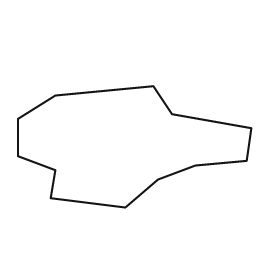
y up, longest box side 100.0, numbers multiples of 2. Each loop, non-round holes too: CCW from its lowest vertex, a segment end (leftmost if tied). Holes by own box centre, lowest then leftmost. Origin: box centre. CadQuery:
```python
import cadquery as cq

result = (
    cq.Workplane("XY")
    .moveTo(-4.0, -26.0)
    .lineTo(10.0, -14.0)
    .lineTo(26.0, -8.0)
    .lineTo(48.0, -6.0)
    .lineTo(50.0, 8.0)
    .lineTo(16.0, 14.0)
    .lineTo(8.0, 26.0)
    .lineTo(-34.0, 22.0)
    .lineTo(-50.0, 12.0)
    .lineTo(-50.0, -4.0)
    .lineTo(-34.0, -10.0)
    .lineTo(-36.0, -22.0)
    .close()
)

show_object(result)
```